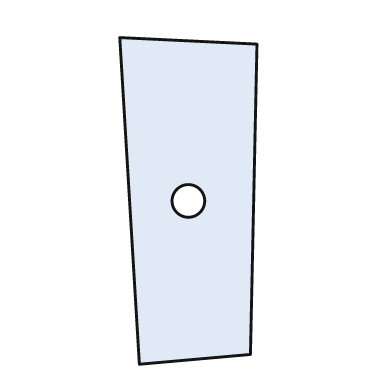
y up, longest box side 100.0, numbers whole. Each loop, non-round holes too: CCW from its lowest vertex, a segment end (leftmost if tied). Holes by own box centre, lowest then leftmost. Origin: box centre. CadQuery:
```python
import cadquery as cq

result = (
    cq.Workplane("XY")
    .moveTo(-15.0, -50.0)
    .lineTo(19.0, -47.0)
    .lineTo(21.0, 48.0)
    .lineTo(-21.0, 50.0)
    .close()
    .moveTo(0.0, 0.0)
    .circle(5.0)
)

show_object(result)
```